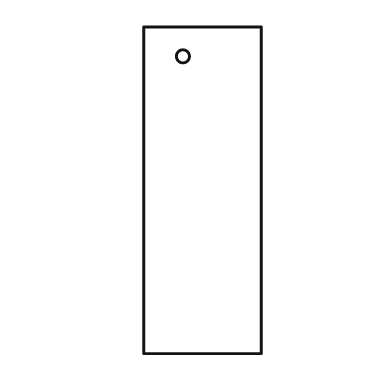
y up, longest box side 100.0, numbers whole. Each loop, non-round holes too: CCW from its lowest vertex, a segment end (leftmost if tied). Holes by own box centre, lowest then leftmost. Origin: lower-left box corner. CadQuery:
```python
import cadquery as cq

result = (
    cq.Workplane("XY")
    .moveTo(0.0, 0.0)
    .lineTo(36.0, 0.0)
    .lineTo(36.0, 100.0)
    .lineTo(0.0, 100.0)
    .close()
    .moveTo(12.0, 91.0)
    .circle(2.0)
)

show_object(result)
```